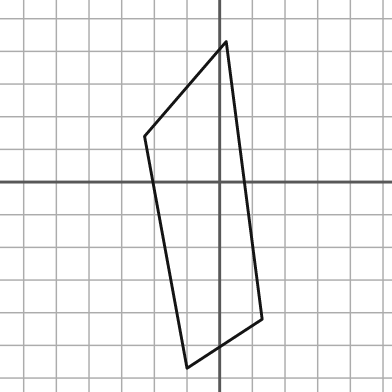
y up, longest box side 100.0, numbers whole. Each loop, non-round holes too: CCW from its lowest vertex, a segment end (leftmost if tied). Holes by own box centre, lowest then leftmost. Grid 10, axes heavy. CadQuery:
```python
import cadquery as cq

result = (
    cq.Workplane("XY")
    .moveTo(-10.0, -57.0)
    .lineTo(13.0, -42.0)
    .lineTo(2.0, 43.0)
    .lineTo(-23.0, 14.0)
    .close()
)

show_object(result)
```